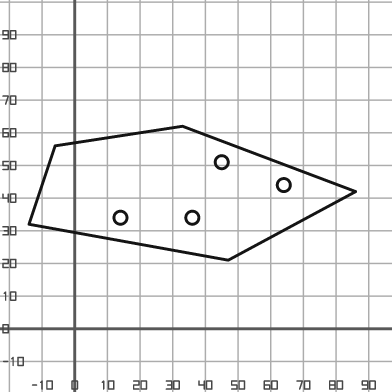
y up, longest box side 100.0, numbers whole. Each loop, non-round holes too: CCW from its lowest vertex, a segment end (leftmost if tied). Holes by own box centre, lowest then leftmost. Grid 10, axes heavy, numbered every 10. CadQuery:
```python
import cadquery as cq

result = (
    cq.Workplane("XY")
    .moveTo(47.0, 21.0)
    .lineTo(86.0, 42.0)
    .lineTo(33.0, 62.0)
    .lineTo(-6.0, 56.0)
    .lineTo(-14.0, 32.0)
    .close()
    .moveTo(14.0, 34.0)
    .circle(2.0)
    .moveTo(36.0, 34.0)
    .circle(2.0)
    .moveTo(64.0, 44.0)
    .circle(2.0)
    .moveTo(45.0, 51.0)
    .circle(2.0)
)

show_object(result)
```